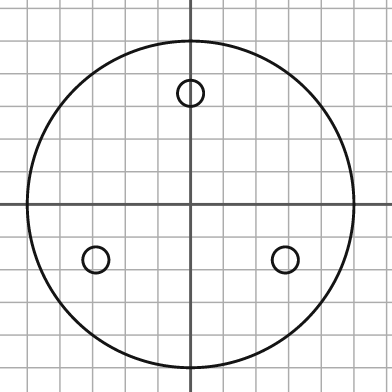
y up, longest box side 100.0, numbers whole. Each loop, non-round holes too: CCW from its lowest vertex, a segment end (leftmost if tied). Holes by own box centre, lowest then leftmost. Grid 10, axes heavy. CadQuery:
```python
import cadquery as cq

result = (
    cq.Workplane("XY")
    .moveTo(0.0, 0.0)
    .circle(50.0)
    .moveTo(-29.0, -17.0)
    .circle(4.0)
    .moveTo(29.0, -17.0)
    .circle(4.0)
    .moveTo(0.0, 34.0)
    .circle(4.0)
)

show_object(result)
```